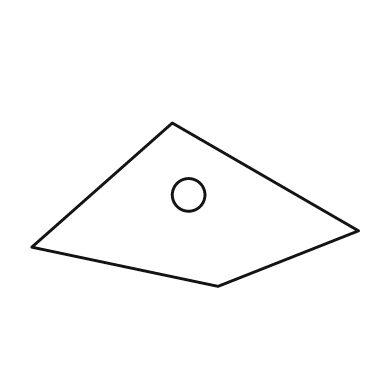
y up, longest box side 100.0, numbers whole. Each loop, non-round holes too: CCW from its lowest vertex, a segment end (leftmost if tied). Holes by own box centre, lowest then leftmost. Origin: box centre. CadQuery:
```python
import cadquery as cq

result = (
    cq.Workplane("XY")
    .moveTo(7.0, -25.0)
    .lineTo(50.0, -8.0)
    .lineTo(-7.0, 25.0)
    .lineTo(-50.0, -13.0)
    .close()
    .moveTo(-2.0, 3.0)
    .circle(5.0)
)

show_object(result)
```